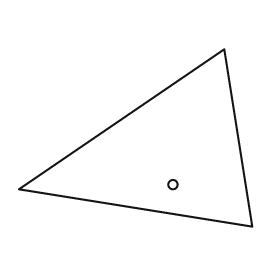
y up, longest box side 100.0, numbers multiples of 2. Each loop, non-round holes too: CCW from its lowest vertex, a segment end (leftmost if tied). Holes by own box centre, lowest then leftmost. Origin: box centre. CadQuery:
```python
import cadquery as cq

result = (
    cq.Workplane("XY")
    .moveTo(50.0, -38.0)
    .lineTo(38.0, 38.0)
    .lineTo(-50.0, -22.0)
    .close()
    .moveTo(16.0, -20.0)
    .circle(2.0)
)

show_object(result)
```